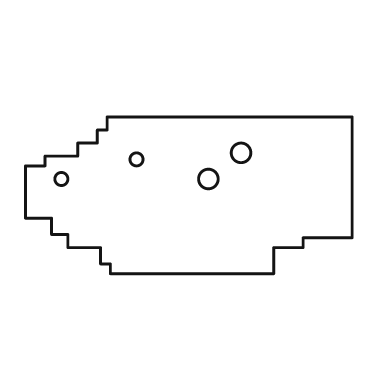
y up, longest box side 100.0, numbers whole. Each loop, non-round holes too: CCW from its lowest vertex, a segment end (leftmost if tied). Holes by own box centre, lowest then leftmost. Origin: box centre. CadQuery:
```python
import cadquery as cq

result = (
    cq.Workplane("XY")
    .moveTo(-24.0, -24.0)
    .lineTo(26.0, -24.0)
    .lineTo(26.0, -16.0)
    .lineTo(35.0, -16.0)
    .lineTo(35.0, -13.0)
    .lineTo(50.0, -13.0)
    .lineTo(50.0, 24.0)
    .lineTo(-25.0, 24.0)
    .lineTo(-25.0, 20.0)
    .lineTo(-28.0, 20.0)
    .lineTo(-28.0, 16.0)
    .lineTo(-34.0, 16.0)
    .lineTo(-34.0, 12.0)
    .lineTo(-44.0, 12.0)
    .lineTo(-44.0, 9.0)
    .lineTo(-50.0, 9.0)
    .lineTo(-50.0, -7.0)
    .lineTo(-42.0, -7.0)
    .lineTo(-42.0, -12.0)
    .lineTo(-37.0, -12.0)
    .lineTo(-37.0, -16.0)
    .lineTo(-27.0, -16.0)
    .lineTo(-27.0, -21.0)
    .lineTo(-24.0, -21.0)
    .close()
    .moveTo(-39.0, 5.0)
    .circle(2.0)
    .moveTo(6.0, 5.0)
    .circle(3.0)
    .moveTo(-16.0, 11.0)
    .circle(2.0)
    .moveTo(16.0, 13.0)
    .circle(3.0)
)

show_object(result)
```